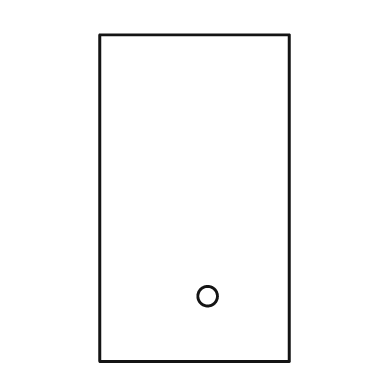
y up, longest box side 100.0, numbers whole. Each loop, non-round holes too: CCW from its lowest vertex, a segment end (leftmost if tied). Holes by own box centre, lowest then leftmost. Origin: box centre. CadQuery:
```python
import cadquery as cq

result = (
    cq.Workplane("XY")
    .moveTo(-29.0, -50.0)
    .lineTo(29.0, -50.0)
    .lineTo(29.0, 50.0)
    .lineTo(-29.0, 50.0)
    .close()
    .moveTo(4.0, -30.0)
    .circle(3.0)
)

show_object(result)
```